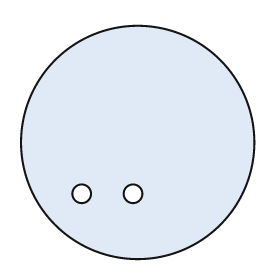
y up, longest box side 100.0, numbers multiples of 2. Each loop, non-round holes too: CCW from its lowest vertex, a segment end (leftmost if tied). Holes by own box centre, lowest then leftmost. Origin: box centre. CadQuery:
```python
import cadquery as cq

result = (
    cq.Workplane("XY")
    .moveTo(0.0, 0.0)
    .circle(50.0)
    .moveTo(-24.0, -22.0)
    .circle(4.0)
    .moveTo(-2.0, -22.0)
    .circle(4.0)
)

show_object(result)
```